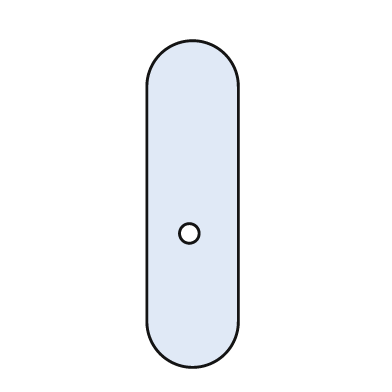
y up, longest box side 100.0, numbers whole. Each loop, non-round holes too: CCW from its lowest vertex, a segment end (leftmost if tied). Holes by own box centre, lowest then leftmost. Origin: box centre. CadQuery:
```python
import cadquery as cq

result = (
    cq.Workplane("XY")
    .moveTo(-14.0, -36.0)
    .threePointArc((0.0, -50.0), (14.0, -36.0))
    .lineTo(14.0, 36.0)
    .threePointArc((0.0, 50.0), (-14.0, 36.0))
    .close()
    .moveTo(-1.0, -9.0)
    .circle(3.0)
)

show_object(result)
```